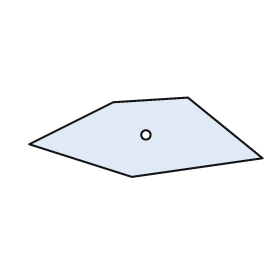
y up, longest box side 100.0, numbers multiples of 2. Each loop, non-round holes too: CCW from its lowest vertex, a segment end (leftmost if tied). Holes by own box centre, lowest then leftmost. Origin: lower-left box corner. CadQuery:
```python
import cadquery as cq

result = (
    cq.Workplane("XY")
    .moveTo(44.0, 0.0)
    .lineTo(100.0, 8.0)
    .lineTo(68.0, 34.0)
    .lineTo(36.0, 32.0)
    .lineTo(0.0, 14.0)
    .close()
    .moveTo(50.0, 18.0)
    .circle(2.0)
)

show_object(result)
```